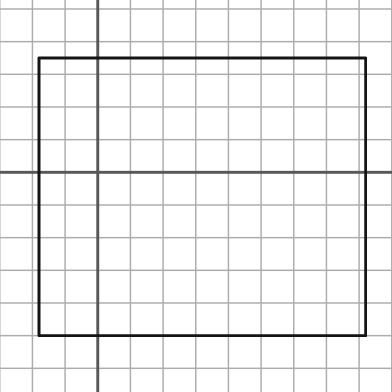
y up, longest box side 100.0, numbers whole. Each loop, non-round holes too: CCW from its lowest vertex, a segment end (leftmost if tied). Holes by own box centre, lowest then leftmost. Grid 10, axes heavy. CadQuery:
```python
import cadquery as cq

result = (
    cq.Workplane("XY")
    .moveTo(-18.0, -50.0)
    .lineTo(82.0, -50.0)
    .lineTo(82.0, 35.0)
    .lineTo(-18.0, 35.0)
    .close()
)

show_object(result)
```